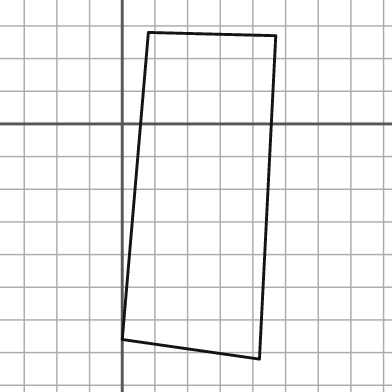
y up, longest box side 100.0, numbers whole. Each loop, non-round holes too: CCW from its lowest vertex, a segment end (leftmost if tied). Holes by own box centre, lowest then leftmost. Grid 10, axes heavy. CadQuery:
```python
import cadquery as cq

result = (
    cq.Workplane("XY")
    .moveTo(42.0, -72.0)
    .lineTo(47.0, 27.0)
    .lineTo(8.0, 28.0)
    .lineTo(0.0, -66.0)
    .close()
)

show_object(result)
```